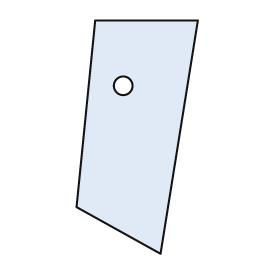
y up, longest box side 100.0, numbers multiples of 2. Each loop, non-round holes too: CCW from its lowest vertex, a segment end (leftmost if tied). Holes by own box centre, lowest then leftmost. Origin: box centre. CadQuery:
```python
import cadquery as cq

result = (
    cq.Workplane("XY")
    .moveTo(10.0, -50.0)
    .lineTo(26.0, 50.0)
    .lineTo(-18.0, 50.0)
    .lineTo(-26.0, -30.0)
    .close()
    .moveTo(-6.0, 22.0)
    .circle(4.0)
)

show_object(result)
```